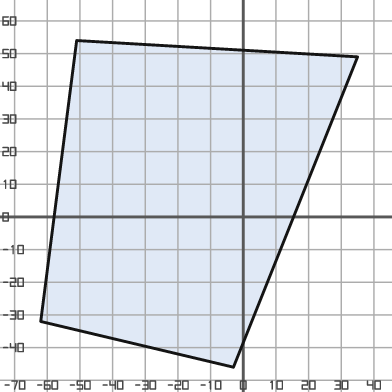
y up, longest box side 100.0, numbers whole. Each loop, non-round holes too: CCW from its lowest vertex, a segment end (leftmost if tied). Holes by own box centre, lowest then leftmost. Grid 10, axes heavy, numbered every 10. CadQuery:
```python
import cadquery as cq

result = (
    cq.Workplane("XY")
    .moveTo(-3.0, -46.0)
    .lineTo(35.0, 49.0)
    .lineTo(-51.0, 54.0)
    .lineTo(-62.0, -32.0)
    .close()
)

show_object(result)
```